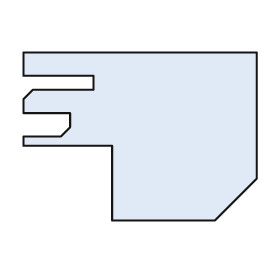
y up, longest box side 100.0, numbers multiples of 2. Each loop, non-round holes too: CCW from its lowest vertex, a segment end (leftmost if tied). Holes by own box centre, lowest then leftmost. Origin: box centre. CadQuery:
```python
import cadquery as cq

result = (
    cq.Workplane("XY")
    .moveTo(-12.0, -36.0)
    .lineTo(32.0, -36.0)
    .lineTo(50.0, -18.0)
    .lineTo(50.0, 36.0)
    .lineTo(-50.0, 36.0)
    .lineTo(-50.0, 26.0)
    .lineTo(-20.0, 26.0)
    .lineTo(-20.0, 20.0)
    .lineTo(-46.0, 20.0)
    .lineTo(-50.0, 16.0)
    .lineTo(-50.0, 10.0)
    .lineTo(-30.0, 10.0)
    .lineTo(-30.0, 4.0)
    .lineTo(-34.0, 0.0)
    .lineTo(-50.0, 0.0)
    .lineTo(-50.0, -4.0)
    .lineTo(-12.0, -4.0)
    .close()
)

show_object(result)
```